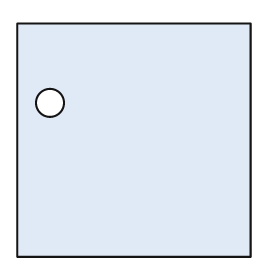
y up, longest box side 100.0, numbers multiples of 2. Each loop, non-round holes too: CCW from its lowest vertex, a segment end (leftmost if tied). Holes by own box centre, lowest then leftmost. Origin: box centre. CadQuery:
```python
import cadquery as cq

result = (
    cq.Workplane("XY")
    .moveTo(-50.0, -50.0)
    .lineTo(50.0, -50.0)
    .lineTo(50.0, 50.0)
    .lineTo(-50.0, 50.0)
    .close()
    .moveTo(-36.0, 16.0)
    .circle(6.0)
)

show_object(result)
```